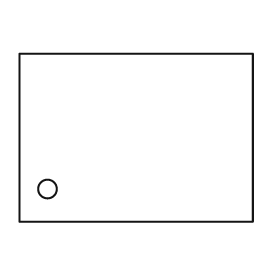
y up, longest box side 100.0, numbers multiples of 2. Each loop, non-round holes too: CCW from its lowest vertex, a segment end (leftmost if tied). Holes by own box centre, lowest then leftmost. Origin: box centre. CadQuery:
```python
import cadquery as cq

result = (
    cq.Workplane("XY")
    .moveTo(-50.0, -36.0)
    .lineTo(50.0, -36.0)
    .lineTo(50.0, 36.0)
    .lineTo(-50.0, 36.0)
    .close()
    .moveTo(-38.0, -22.0)
    .circle(4.0)
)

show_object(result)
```